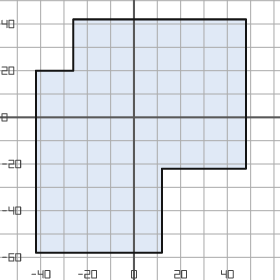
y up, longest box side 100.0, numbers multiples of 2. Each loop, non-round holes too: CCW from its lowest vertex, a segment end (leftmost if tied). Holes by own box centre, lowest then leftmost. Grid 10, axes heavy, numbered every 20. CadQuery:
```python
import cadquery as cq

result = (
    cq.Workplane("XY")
    .moveTo(-42.0, -58.0)
    .lineTo(12.0, -58.0)
    .lineTo(12.0, -22.0)
    .lineTo(48.0, -22.0)
    .lineTo(48.0, 42.0)
    .lineTo(-26.0, 42.0)
    .lineTo(-26.0, 20.0)
    .lineTo(-42.0, 20.0)
    .close()
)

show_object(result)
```